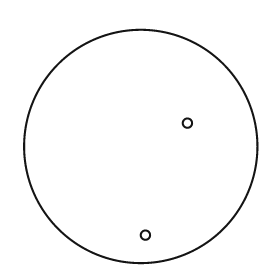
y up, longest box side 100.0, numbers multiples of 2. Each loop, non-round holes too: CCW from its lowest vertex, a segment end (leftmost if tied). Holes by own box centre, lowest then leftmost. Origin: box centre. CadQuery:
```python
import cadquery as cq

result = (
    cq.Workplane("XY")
    .moveTo(0.0, 0.0)
    .circle(50.0)
    .moveTo(2.0, -38.0)
    .circle(2.0)
    .moveTo(20.0, 10.0)
    .circle(2.0)
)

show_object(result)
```